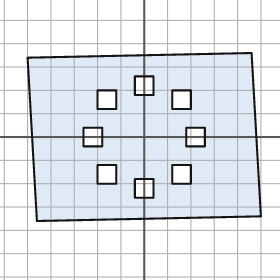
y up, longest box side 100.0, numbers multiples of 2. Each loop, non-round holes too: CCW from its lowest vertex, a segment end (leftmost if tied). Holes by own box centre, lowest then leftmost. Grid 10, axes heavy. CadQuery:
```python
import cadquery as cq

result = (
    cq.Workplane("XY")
    .moveTo(-46.0, -36.0)
    .lineTo(50.0, -34.0)
    .lineTo(46.0, 36.0)
    .lineTo(-50.0, 34.0)
    .close()
    .moveTo(-4.0, -26.0)
    .lineTo(4.0, -26.0)
    .lineTo(4.0, -18.0)
    .lineTo(-4.0, -18.0)
    .close()
    .moveTo(-20.0, -20.0)
    .lineTo(-12.0, -20.0)
    .lineTo(-12.0, -12.0)
    .lineTo(-20.0, -12.0)
    .close()
    .moveTo(12.0, -20.0)
    .lineTo(20.0, -20.0)
    .lineTo(20.0, -12.0)
    .lineTo(12.0, -12.0)
    .close()
    .moveTo(-26.0, -4.0)
    .lineTo(-18.0, -4.0)
    .lineTo(-18.0, 4.0)
    .lineTo(-26.0, 4.0)
    .close()
    .moveTo(18.0, -4.0)
    .lineTo(26.0, -4.0)
    .lineTo(26.0, 4.0)
    .lineTo(18.0, 4.0)
    .close()
    .moveTo(-20.0, 12.0)
    .lineTo(-12.0, 12.0)
    .lineTo(-12.0, 20.0)
    .lineTo(-20.0, 20.0)
    .close()
    .moveTo(12.0, 12.0)
    .lineTo(20.0, 12.0)
    .lineTo(20.0, 20.0)
    .lineTo(12.0, 20.0)
    .close()
    .moveTo(-4.0, 18.0)
    .lineTo(4.0, 18.0)
    .lineTo(4.0, 26.0)
    .lineTo(-4.0, 26.0)
    .close()
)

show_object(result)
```